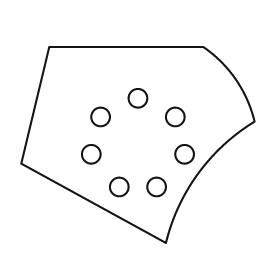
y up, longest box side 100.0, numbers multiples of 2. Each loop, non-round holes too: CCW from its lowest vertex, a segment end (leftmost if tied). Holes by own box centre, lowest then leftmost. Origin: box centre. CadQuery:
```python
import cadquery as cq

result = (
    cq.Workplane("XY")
    .moveTo(12.0, -42.0)
    .threePointArc((26.0, -12.0), (50.0, 10.0))
    .threePointArc((42.0, 28.0), (28.0, 42.0))
    .lineTo(-38.0, 42.0)
    .lineTo(-50.0, -8.0)
    .close()
    .moveTo(-8.0, -18.0)
    .circle(4.0)
    .moveTo(8.0, -18.0)
    .circle(4.0)
    .moveTo(-20.0, -4.0)
    .circle(4.0)
    .moveTo(20.0, -4.0)
    .circle(4.0)
    .moveTo(-16.0, 12.0)
    .circle(4.0)
    .moveTo(16.0, 12.0)
    .circle(4.0)
    .moveTo(0.0, 20.0)
    .circle(4.0)
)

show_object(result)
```